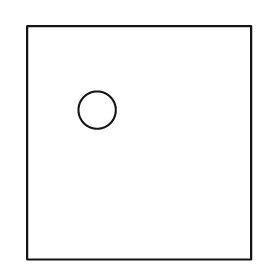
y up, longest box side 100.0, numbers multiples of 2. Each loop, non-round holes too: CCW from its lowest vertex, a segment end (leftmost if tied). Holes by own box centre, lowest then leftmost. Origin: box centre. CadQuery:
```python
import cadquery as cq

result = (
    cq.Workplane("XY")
    .moveTo(-48.0, -50.0)
    .lineTo(48.0, -50.0)
    .lineTo(48.0, 50.0)
    .lineTo(-48.0, 50.0)
    .close()
    .moveTo(-18.0, 14.0)
    .circle(8.0)
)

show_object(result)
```